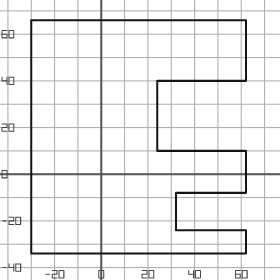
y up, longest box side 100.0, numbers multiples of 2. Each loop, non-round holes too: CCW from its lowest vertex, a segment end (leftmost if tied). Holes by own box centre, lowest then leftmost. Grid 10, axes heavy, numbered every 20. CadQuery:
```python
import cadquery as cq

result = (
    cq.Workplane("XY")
    .moveTo(-30.0, -34.0)
    .lineTo(62.0, -34.0)
    .lineTo(62.0, -24.0)
    .lineTo(32.0, -24.0)
    .lineTo(32.0, -8.0)
    .lineTo(62.0, -8.0)
    .lineTo(62.0, 10.0)
    .lineTo(24.0, 10.0)
    .lineTo(24.0, 40.0)
    .lineTo(62.0, 40.0)
    .lineTo(62.0, 66.0)
    .lineTo(-30.0, 66.0)
    .close()
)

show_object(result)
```